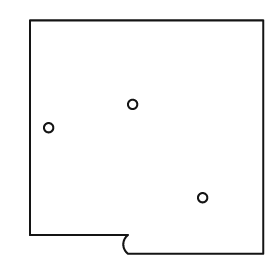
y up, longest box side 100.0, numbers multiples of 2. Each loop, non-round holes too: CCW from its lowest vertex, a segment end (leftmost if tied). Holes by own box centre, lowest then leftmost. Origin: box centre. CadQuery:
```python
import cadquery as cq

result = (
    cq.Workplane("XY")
    .moveTo(-8.0, -50.0)
    .lineTo(50.0, -50.0)
    .lineTo(50.0, 50.0)
    .lineTo(-50.0, 50.0)
    .lineTo(-50.0, -42.0)
    .lineTo(-8.0, -42.0)
    .threePointArc((-10.0, -46.0), (-8.0, -50.0))
    .close()
    .moveTo(24.0, -26.0)
    .circle(2.0)
    .moveTo(-42.0, 4.0)
    .circle(2.0)
    .moveTo(-6.0, 14.0)
    .circle(2.0)
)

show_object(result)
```